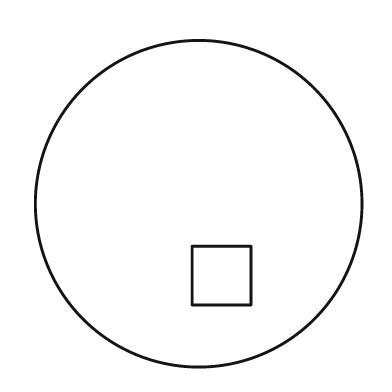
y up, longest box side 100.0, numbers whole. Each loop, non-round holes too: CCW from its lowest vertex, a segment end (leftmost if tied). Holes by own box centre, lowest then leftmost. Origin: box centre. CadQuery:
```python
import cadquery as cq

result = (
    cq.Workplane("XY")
    .moveTo(0.0, 0.0)
    .circle(50.0)
    .moveTo(-2.0, -31.0)
    .lineTo(16.0, -31.0)
    .lineTo(16.0, -13.0)
    .lineTo(-2.0, -13.0)
    .close()
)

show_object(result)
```